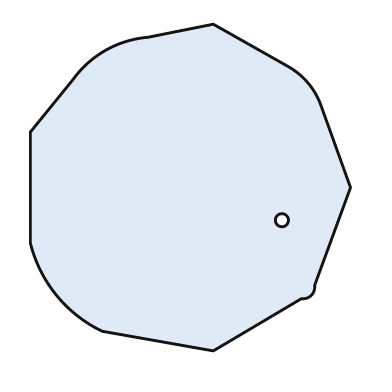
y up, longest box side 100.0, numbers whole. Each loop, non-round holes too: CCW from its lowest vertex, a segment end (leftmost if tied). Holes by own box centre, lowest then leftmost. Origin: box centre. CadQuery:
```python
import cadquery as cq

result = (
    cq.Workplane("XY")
    .moveTo(7.0, -50.0)
    .lineTo(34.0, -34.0)
    .threePointArc((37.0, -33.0), (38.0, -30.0))
    .lineTo(49.0, 0.0)
    .lineTo(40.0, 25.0)
    .threePointArc((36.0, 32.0), (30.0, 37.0))
    .lineTo(7.0, 50.0)
    .lineTo(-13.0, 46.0)
    .threePointArc((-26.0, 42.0), (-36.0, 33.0))
    .lineTo(-49.0, 17.0)
    .lineTo(-49.0, -17.0)
    .threePointArc((-41.0, -33.0), (-27.0, -44.0))
    .close()
    .moveTo(28.0, -10.0)
    .circle(2.0)
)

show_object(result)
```